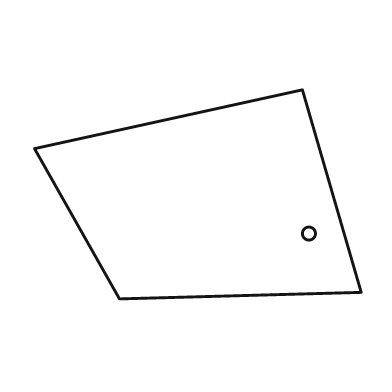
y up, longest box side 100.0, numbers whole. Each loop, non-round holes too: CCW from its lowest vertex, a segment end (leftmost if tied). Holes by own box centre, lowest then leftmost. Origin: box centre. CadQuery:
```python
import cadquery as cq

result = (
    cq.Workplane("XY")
    .moveTo(-24.0, -32.0)
    .lineTo(50.0, -30.0)
    .lineTo(32.0, 32.0)
    .lineTo(-50.0, 14.0)
    .close()
    .moveTo(34.0, -12.0)
    .circle(2.0)
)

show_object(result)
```